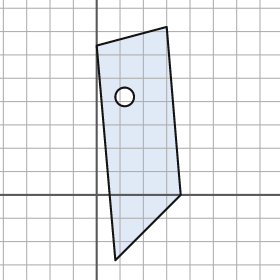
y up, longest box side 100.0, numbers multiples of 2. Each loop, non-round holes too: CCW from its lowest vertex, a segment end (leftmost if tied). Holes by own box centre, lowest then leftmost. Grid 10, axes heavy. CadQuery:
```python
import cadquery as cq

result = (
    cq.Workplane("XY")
    .moveTo(8.0, -28.0)
    .lineTo(36.0, 0.0)
    .lineTo(30.0, 72.0)
    .lineTo(0.0, 64.0)
    .close()
    .moveTo(12.0, 42.0)
    .circle(4.0)
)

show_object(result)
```